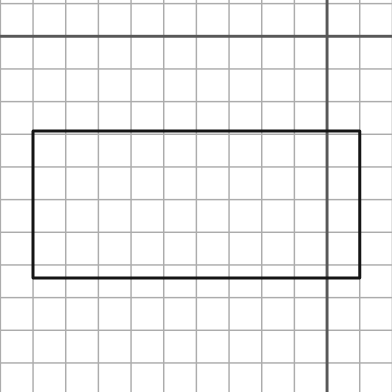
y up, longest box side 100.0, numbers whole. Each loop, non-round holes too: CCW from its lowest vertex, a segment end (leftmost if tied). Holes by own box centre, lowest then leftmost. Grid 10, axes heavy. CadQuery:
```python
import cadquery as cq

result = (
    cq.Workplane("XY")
    .moveTo(-90.0, -74.0)
    .lineTo(10.0, -74.0)
    .lineTo(10.0, -29.0)
    .lineTo(-90.0, -29.0)
    .close()
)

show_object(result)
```